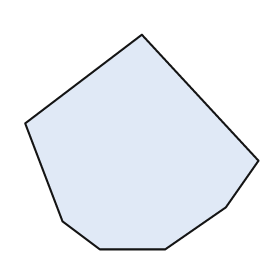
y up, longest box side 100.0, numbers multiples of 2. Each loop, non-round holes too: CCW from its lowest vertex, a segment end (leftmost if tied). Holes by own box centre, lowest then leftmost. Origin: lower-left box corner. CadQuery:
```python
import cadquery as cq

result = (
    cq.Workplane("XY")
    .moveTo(32.0, 0.0)
    .lineTo(60.0, 0.0)
    .lineTo(86.0, 18.0)
    .lineTo(100.0, 38.0)
    .lineTo(50.0, 92.0)
    .lineTo(0.0, 54.0)
    .lineTo(16.0, 12.0)
    .close()
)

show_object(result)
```